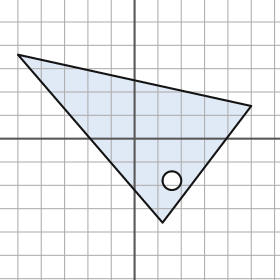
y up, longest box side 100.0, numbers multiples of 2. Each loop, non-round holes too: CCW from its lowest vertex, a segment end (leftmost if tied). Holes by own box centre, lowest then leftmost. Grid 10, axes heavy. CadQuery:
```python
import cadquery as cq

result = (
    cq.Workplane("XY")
    .moveTo(12.0, -36.0)
    .lineTo(50.0, 14.0)
    .lineTo(-50.0, 36.0)
    .close()
    .moveTo(16.0, -18.0)
    .circle(4.0)
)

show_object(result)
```